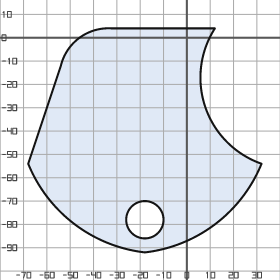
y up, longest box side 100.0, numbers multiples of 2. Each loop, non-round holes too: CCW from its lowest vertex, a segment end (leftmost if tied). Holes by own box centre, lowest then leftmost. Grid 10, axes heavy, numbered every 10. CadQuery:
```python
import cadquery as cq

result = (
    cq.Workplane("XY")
    .moveTo(-18.0, -92.0)
    .threePointArc((12.0, -80.0), (32.0, -54.0))
    .threePointArc((8.0, -30.0), (12.0, 4.0))
    .lineTo(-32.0, 4.0)
    .threePointArc((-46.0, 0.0), (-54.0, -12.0))
    .lineTo(-68.0, -54.0)
    .threePointArc((-48.0, -80.0), (-18.0, -92.0))
    .close()
    .moveTo(-18.0, -78.0)
    .circle(8.0)
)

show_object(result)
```